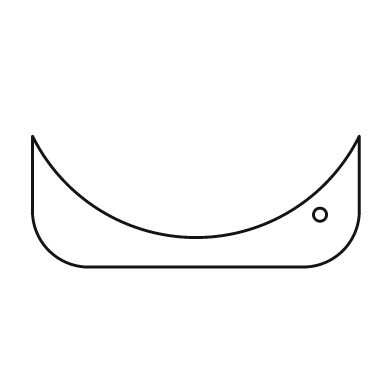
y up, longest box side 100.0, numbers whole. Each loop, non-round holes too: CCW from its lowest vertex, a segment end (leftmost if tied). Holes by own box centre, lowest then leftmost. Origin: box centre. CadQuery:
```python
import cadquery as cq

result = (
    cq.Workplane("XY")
    .moveTo(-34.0, -20.0)
    .lineTo(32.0, -20.0)
    .threePointArc((45.0, -15.0), (50.0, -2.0))
    .lineTo(50.0, 20.0)
    .threePointArc((0.0, -11.0), (-50.0, 20.0))
    .lineTo(-50.0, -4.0)
    .threePointArc((-45.0, -15.0), (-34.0, -20.0))
    .close()
    .moveTo(38.0, -4.0)
    .circle(2.0)
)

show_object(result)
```